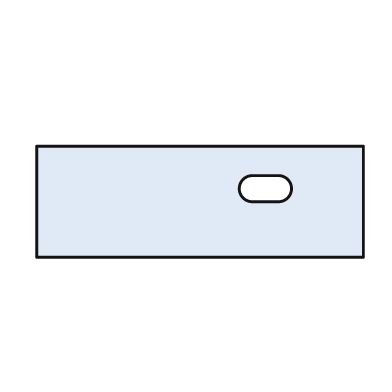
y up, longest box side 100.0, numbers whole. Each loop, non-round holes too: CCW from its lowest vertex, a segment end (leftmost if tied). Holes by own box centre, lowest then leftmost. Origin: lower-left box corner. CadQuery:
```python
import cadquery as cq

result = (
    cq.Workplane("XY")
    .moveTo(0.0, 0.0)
    .lineTo(100.0, 0.0)
    .lineTo(100.0, 34.0)
    .lineTo(0.0, 34.0)
    .close()
    .moveTo(66.0, 17.0)
    .lineTo(74.0, 17.0)
    .threePointArc((78.0, 21.0), (74.0, 25.0))
    .lineTo(66.0, 25.0)
    .threePointArc((62.0, 21.0), (66.0, 17.0))
    .close()
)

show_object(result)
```